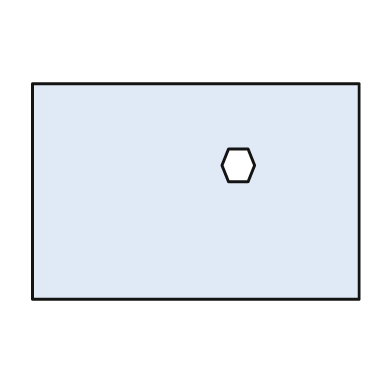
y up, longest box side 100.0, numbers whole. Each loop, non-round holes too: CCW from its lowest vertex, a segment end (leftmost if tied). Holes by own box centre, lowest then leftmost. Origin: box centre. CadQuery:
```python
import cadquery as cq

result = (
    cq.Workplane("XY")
    .moveTo(-50.0, -33.0)
    .lineTo(50.0, -33.0)
    .lineTo(50.0, 33.0)
    .lineTo(-50.0, 33.0)
    .close()
    .moveTo(10.0, 3.0)
    .lineTo(16.0, 3.0)
    .lineTo(18.0, 8.0)
    .lineTo(16.0, 13.0)
    .lineTo(10.0, 13.0)
    .lineTo(8.0, 8.0)
    .close()
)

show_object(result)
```